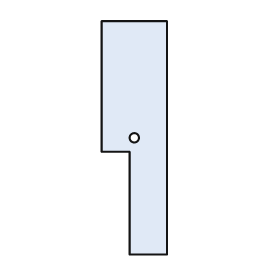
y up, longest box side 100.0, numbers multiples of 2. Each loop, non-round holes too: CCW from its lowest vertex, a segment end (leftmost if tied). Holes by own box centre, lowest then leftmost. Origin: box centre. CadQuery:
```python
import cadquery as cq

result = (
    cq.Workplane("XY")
    .moveTo(-2.0, -50.0)
    .lineTo(14.0, -50.0)
    .lineTo(14.0, 50.0)
    .lineTo(-14.0, 50.0)
    .lineTo(-14.0, -6.0)
    .lineTo(-2.0, -6.0)
    .close()
    .moveTo(0.0, 0.0)
    .circle(2.0)
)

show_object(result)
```